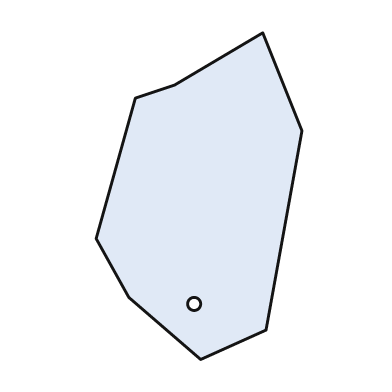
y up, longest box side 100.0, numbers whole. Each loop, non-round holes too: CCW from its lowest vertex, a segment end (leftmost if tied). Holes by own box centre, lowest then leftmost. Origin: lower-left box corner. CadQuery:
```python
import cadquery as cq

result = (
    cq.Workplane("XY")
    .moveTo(32.0, 0.0)
    .lineTo(52.0, 9.0)
    .lineTo(63.0, 70.0)
    .lineTo(51.0, 100.0)
    .lineTo(24.0, 84.0)
    .lineTo(12.0, 80.0)
    .lineTo(0.0, 37.0)
    .lineTo(10.0, 19.0)
    .close()
    .moveTo(30.0, 17.0)
    .circle(2.0)
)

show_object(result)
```